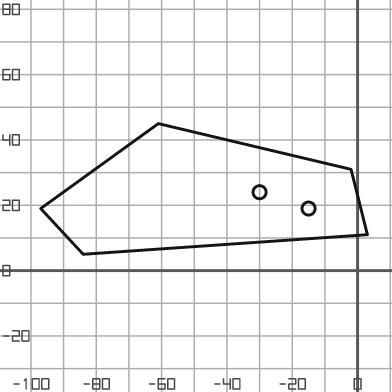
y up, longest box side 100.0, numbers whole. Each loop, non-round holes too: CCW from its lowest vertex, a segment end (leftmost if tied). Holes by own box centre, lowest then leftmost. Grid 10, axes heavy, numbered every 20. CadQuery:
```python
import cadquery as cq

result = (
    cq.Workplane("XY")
    .moveTo(-84.0, 5.0)
    .lineTo(3.0, 11.0)
    .lineTo(-2.0, 31.0)
    .lineTo(-61.0, 45.0)
    .lineTo(-97.0, 19.0)
    .close()
    .moveTo(-15.0, 19.0)
    .circle(2.0)
    .moveTo(-30.0, 24.0)
    .circle(2.0)
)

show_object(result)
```